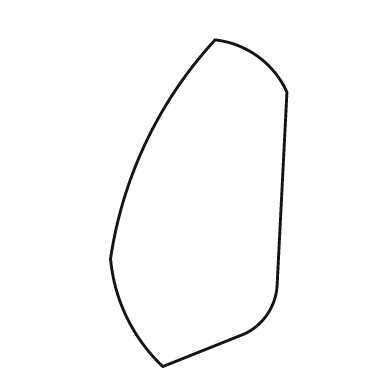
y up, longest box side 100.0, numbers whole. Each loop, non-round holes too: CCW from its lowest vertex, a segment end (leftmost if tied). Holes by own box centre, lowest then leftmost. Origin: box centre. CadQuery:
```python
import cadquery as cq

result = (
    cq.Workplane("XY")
    .moveTo(-11.0, -50.0)
    .lineTo(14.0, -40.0)
    .threePointArc((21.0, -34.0), (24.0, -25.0))
    .lineTo(27.0, 34.0)
    .threePointArc((18.0, 45.0), (5.0, 50.0))
    .threePointArc((-16.0, 19.0), (-27.0, -17.0))
    .threePointArc((-22.0, -35.0), (-11.0, -50.0))
    .close()
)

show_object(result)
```